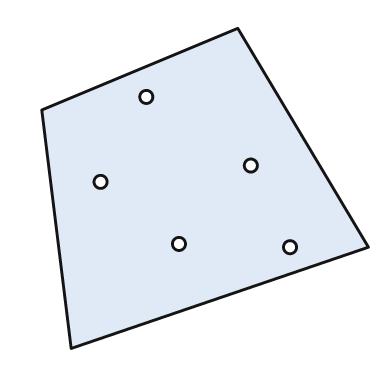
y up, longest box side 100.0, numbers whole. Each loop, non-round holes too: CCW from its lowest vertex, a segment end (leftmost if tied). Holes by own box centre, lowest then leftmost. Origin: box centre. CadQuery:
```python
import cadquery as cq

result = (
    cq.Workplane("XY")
    .moveTo(-41.0, -49.0)
    .lineTo(50.0, -18.0)
    .lineTo(10.0, 49.0)
    .lineTo(-50.0, 24.0)
    .close()
    .moveTo(26.0, -18.0)
    .circle(2.0)
    .moveTo(-8.0, -17.0)
    .circle(2.0)
    .moveTo(-32.0, 2.0)
    .circle(2.0)
    .moveTo(14.0, 7.0)
    .circle(2.0)
    .moveTo(-18.0, 28.0)
    .circle(2.0)
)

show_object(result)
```